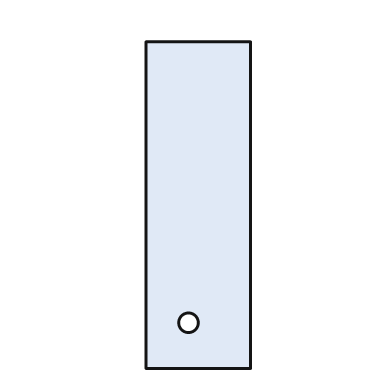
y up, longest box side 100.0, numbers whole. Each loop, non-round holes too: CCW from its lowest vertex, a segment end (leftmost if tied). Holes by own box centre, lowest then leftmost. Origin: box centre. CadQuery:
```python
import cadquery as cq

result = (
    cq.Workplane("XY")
    .moveTo(-16.0, -50.0)
    .lineTo(16.0, -50.0)
    .lineTo(16.0, 50.0)
    .lineTo(-16.0, 50.0)
    .close()
    .moveTo(-3.0, -36.0)
    .circle(3.0)
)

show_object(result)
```